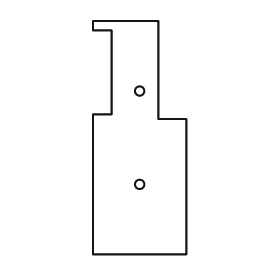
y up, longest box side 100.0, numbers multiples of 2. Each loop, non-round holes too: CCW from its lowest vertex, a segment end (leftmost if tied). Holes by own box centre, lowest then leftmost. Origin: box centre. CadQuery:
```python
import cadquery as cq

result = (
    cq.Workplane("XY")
    .moveTo(-20.0, -50.0)
    .lineTo(20.0, -50.0)
    .lineTo(20.0, 8.0)
    .lineTo(8.0, 8.0)
    .lineTo(8.0, 50.0)
    .lineTo(-20.0, 50.0)
    .lineTo(-20.0, 46.0)
    .lineTo(-12.0, 46.0)
    .lineTo(-12.0, 10.0)
    .lineTo(-20.0, 10.0)
    .close()
    .moveTo(0.0, -20.0)
    .circle(2.0)
    .moveTo(0.0, 20.0)
    .circle(2.0)
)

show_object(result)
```